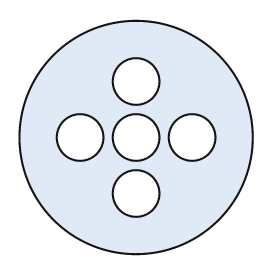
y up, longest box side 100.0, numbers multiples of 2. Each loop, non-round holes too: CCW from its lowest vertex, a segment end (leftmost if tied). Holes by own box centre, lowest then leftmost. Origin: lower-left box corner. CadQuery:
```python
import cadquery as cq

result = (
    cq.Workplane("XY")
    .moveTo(50.0, 50.0)
    .circle(50.0)
    .moveTo(50.0, 26.0)
    .circle(10.0)
    .moveTo(26.0, 50.0)
    .circle(10.0)
    .moveTo(50.0, 50.0)
    .circle(10.0)
    .moveTo(74.0, 50.0)
    .circle(10.0)
    .moveTo(50.0, 74.0)
    .circle(10.0)
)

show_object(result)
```